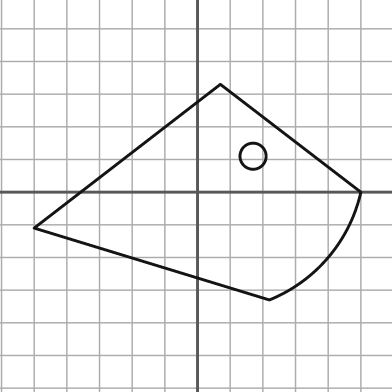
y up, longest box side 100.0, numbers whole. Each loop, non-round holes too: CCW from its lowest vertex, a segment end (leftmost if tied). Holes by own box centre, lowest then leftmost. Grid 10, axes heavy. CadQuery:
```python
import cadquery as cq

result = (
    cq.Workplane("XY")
    .moveTo(22.0, -33.0)
    .threePointArc((40.0, -20.0), (50.0, 0.0))
    .lineTo(7.0, 33.0)
    .lineTo(-50.0, -11.0)
    .close()
    .moveTo(17.0, 11.0)
    .circle(4.0)
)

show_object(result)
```